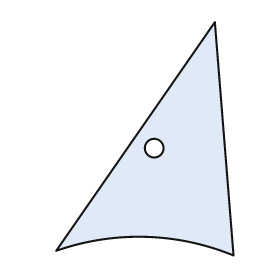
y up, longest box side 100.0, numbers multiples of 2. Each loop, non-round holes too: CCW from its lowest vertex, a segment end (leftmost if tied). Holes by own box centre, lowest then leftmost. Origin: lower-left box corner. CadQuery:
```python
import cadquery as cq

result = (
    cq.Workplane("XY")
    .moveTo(76.0, 0.0)
    .lineTo(68.0, 100.0)
    .lineTo(0.0, 2.0)
    .threePointArc((38.0, 8.0), (76.0, 0.0))
    .close()
    .moveTo(42.0, 46.0)
    .circle(4.0)
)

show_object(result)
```